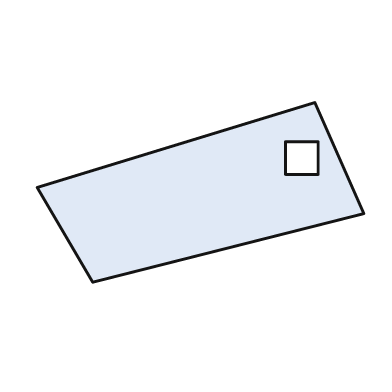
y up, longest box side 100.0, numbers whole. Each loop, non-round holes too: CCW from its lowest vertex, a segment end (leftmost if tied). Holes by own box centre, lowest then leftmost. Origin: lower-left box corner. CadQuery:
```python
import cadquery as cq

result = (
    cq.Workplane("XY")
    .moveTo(17.0, 0.0)
    .lineTo(100.0, 21.0)
    .lineTo(85.0, 55.0)
    .lineTo(0.0, 29.0)
    .close()
    .moveTo(76.0, 33.0)
    .lineTo(86.0, 33.0)
    .lineTo(86.0, 43.0)
    .lineTo(76.0, 43.0)
    .close()
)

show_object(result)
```